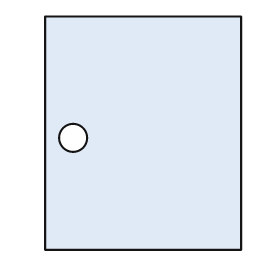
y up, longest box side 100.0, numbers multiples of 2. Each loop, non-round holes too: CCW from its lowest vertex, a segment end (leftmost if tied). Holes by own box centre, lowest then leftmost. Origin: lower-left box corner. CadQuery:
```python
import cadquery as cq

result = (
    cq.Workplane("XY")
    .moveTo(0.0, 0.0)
    .lineTo(84.0, 0.0)
    .lineTo(84.0, 100.0)
    .lineTo(0.0, 100.0)
    .close()
    .moveTo(12.0, 48.0)
    .circle(6.0)
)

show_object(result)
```